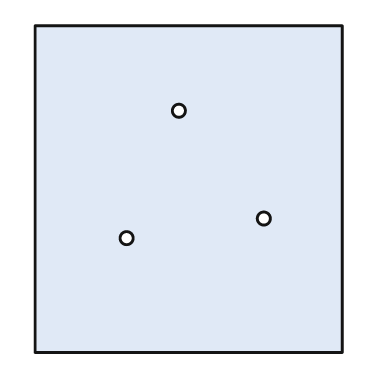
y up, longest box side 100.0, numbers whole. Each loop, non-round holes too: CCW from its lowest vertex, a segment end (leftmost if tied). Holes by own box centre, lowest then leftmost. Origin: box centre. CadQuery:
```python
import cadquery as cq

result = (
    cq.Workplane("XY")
    .moveTo(-47.0, -50.0)
    .lineTo(47.0, -50.0)
    .lineTo(47.0, 50.0)
    .lineTo(-47.0, 50.0)
    .close()
    .moveTo(-19.0, -15.0)
    .circle(2.0)
    .moveTo(23.0, -9.0)
    .circle(2.0)
    .moveTo(-3.0, 24.0)
    .circle(2.0)
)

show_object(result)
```